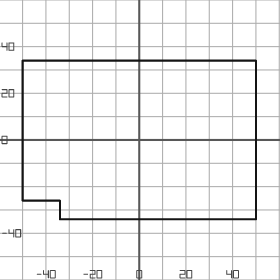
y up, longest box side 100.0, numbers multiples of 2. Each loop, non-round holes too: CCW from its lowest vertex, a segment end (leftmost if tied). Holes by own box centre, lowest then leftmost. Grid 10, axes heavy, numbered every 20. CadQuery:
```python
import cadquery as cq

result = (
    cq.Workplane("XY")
    .moveTo(-34.0, -34.0)
    .lineTo(50.0, -34.0)
    .lineTo(50.0, 34.0)
    .lineTo(-50.0, 34.0)
    .lineTo(-50.0, -26.0)
    .lineTo(-34.0, -26.0)
    .close()
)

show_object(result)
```